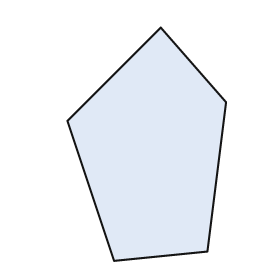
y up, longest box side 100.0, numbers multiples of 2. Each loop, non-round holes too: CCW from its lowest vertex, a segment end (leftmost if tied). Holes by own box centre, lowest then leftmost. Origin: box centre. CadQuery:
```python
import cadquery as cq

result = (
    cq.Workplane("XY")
    .moveTo(-14.0, -50.0)
    .lineTo(26.0, -46.0)
    .lineTo(34.0, 18.0)
    .lineTo(6.0, 50.0)
    .lineTo(-34.0, 10.0)
    .close()
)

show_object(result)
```